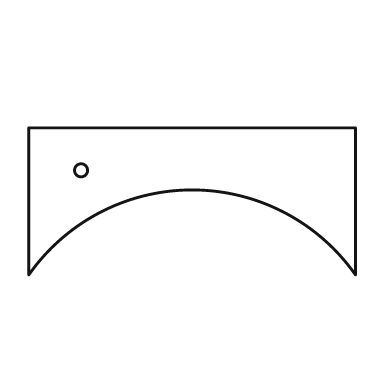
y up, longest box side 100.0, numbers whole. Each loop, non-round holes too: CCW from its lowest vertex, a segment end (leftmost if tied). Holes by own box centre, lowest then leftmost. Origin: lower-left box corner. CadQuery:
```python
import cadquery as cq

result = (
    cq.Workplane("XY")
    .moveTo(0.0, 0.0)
    .threePointArc((50.0, 26.0), (100.0, 0.0))
    .lineTo(100.0, 45.0)
    .lineTo(0.0, 45.0)
    .close()
    .moveTo(16.0, 32.0)
    .circle(2.0)
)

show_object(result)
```